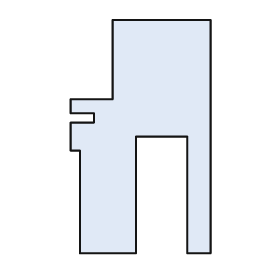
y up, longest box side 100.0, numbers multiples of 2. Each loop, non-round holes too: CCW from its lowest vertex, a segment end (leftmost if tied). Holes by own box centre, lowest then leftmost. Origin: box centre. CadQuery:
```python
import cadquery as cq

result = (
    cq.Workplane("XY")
    .moveTo(-26.0, -50.0)
    .lineTo(-2.0, -50.0)
    .lineTo(-2.0, 0.0)
    .lineTo(20.0, 0.0)
    .lineTo(20.0, -50.0)
    .lineTo(30.0, -50.0)
    .lineTo(30.0, 50.0)
    .lineTo(-12.0, 50.0)
    .lineTo(-12.0, 16.0)
    .lineTo(-30.0, 16.0)
    .lineTo(-30.0, 10.0)
    .lineTo(-20.0, 10.0)
    .lineTo(-20.0, 6.0)
    .lineTo(-30.0, 6.0)
    .lineTo(-30.0, -6.0)
    .lineTo(-26.0, -6.0)
    .close()
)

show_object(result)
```